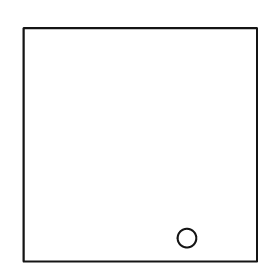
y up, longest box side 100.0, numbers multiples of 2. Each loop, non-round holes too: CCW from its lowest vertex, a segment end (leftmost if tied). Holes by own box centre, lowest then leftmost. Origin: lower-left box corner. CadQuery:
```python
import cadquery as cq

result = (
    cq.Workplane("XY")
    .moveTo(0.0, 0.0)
    .lineTo(100.0, 0.0)
    .lineTo(100.0, 100.0)
    .lineTo(0.0, 100.0)
    .close()
    .moveTo(70.0, 10.0)
    .circle(4.0)
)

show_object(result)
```